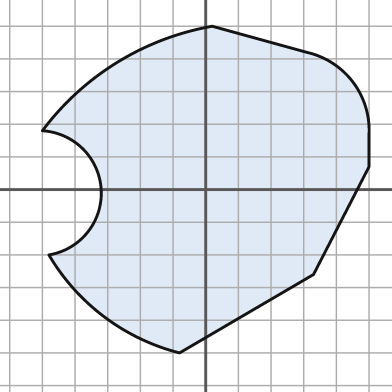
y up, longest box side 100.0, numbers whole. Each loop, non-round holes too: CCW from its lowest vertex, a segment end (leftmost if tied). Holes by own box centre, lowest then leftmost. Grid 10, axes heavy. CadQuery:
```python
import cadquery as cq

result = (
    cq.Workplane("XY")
    .moveTo(-8.0, -50.0)
    .lineTo(33.0, -26.0)
    .lineTo(50.0, 7.0)
    .lineTo(50.0, 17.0)
    .threePointArc((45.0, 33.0), (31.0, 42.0))
    .lineTo(2.0, 50.0)
    .threePointArc((-27.0, 39.0), (-50.0, 18.0))
    .threePointArc((-32.0, 0.0), (-48.0, -20.0))
    .threePointArc((-31.0, -39.0), (-8.0, -50.0))
    .close()
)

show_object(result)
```